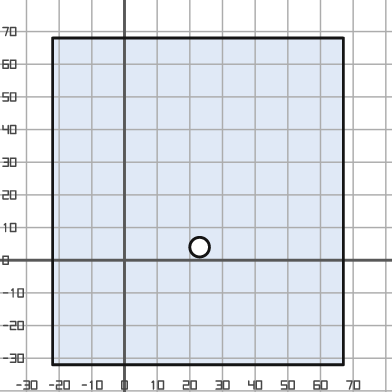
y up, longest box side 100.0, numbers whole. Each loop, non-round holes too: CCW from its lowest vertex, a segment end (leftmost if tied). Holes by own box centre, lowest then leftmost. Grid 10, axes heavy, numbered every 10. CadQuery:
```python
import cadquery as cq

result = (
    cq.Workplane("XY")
    .moveTo(-22.0, -32.0)
    .lineTo(67.0, -32.0)
    .lineTo(67.0, 68.0)
    .lineTo(-22.0, 68.0)
    .close()
    .moveTo(23.0, 4.0)
    .circle(3.0)
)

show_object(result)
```